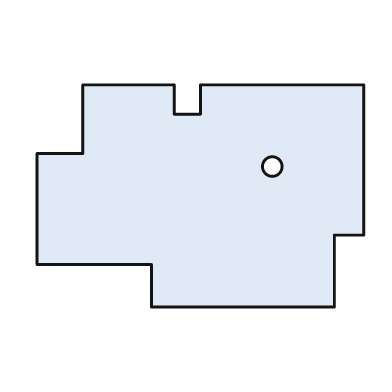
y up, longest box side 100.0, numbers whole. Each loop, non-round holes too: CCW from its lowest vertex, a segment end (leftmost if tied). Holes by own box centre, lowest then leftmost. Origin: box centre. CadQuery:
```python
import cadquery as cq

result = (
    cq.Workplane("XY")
    .moveTo(-15.0, -34.0)
    .lineTo(41.0, -34.0)
    .lineTo(41.0, -12.0)
    .lineTo(50.0, -12.0)
    .lineTo(50.0, 34.0)
    .lineTo(0.0, 34.0)
    .lineTo(0.0, 25.0)
    .lineTo(-8.0, 25.0)
    .lineTo(-8.0, 34.0)
    .lineTo(-36.0, 34.0)
    .lineTo(-36.0, 13.0)
    .lineTo(-50.0, 13.0)
    .lineTo(-50.0, -21.0)
    .lineTo(-15.0, -21.0)
    .close()
    .moveTo(22.0, 9.0)
    .circle(3.0)
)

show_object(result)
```